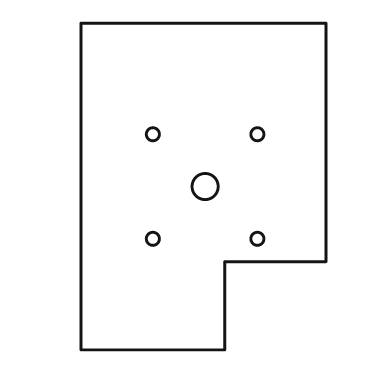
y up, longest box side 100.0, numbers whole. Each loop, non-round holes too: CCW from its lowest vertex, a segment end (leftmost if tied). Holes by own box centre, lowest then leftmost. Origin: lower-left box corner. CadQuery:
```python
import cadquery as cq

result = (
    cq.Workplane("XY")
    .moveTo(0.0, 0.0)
    .lineTo(44.0, 0.0)
    .lineTo(44.0, 27.0)
    .lineTo(75.0, 27.0)
    .lineTo(75.0, 100.0)
    .lineTo(0.0, 100.0)
    .close()
    .moveTo(22.0, 34.0)
    .circle(2.0)
    .moveTo(54.0, 34.0)
    .circle(2.0)
    .moveTo(38.0, 50.0)
    .circle(4.0)
    .moveTo(22.0, 66.0)
    .circle(2.0)
    .moveTo(54.0, 66.0)
    .circle(2.0)
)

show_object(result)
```